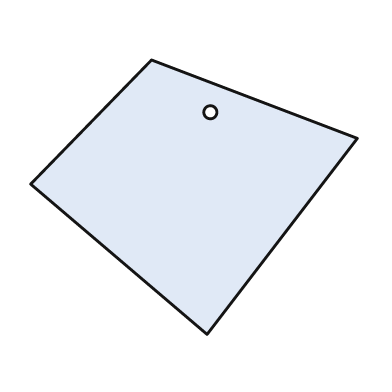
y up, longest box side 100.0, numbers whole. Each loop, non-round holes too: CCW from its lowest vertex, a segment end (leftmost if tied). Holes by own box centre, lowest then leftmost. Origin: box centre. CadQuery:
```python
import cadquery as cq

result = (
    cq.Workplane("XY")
    .moveTo(4.0, -42.0)
    .lineTo(50.0, 18.0)
    .lineTo(-13.0, 42.0)
    .lineTo(-50.0, 4.0)
    .close()
    .moveTo(5.0, 26.0)
    .circle(2.0)
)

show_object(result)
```